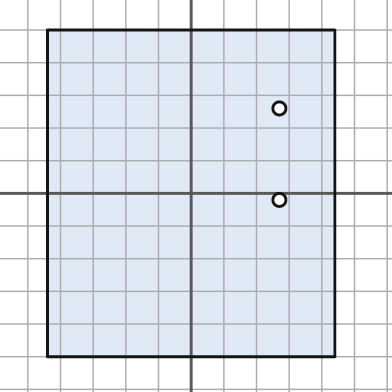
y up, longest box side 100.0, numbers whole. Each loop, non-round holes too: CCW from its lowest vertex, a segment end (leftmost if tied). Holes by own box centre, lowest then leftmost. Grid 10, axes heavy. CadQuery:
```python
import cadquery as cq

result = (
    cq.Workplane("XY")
    .moveTo(-44.0, -50.0)
    .lineTo(44.0, -50.0)
    .lineTo(44.0, 50.0)
    .lineTo(-44.0, 50.0)
    .close()
    .moveTo(27.0, -2.0)
    .circle(2.0)
    .moveTo(27.0, 26.0)
    .circle(2.0)
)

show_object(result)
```